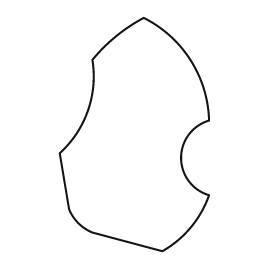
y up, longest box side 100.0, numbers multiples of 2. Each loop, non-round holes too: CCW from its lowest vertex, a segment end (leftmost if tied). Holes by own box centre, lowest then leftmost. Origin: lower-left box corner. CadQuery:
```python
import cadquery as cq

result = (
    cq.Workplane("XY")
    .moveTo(44.0, 0.0)
    .threePointArc((56.0, 10.0), (64.0, 24.0))
    .threePointArc((52.0, 40.0), (64.0, 56.0))
    .threePointArc((56.0, 82.0), (36.0, 100.0))
    .threePointArc((24.0, 92.0), (14.0, 82.0))
    .threePointArc((12.0, 60.0), (0.0, 42.0))
    .lineTo(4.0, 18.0)
    .threePointArc((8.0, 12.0), (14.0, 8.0))
    .close()
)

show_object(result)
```